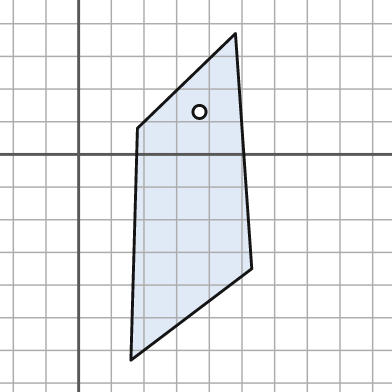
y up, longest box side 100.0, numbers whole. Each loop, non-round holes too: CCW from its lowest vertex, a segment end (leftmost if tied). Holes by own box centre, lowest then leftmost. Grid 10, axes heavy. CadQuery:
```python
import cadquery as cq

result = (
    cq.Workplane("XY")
    .moveTo(16.0, -63.0)
    .lineTo(53.0, -35.0)
    .lineTo(48.0, 37.0)
    .lineTo(18.0, 8.0)
    .close()
    .moveTo(37.0, 13.0)
    .circle(2.0)
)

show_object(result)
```